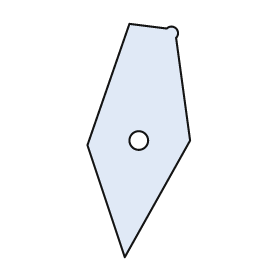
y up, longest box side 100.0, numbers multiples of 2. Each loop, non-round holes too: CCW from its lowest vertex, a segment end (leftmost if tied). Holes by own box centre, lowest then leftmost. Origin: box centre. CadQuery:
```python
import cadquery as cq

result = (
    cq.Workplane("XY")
    .moveTo(-6.0, -50.0)
    .lineTo(22.0, 0.0)
    .lineTo(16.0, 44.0)
    .threePointArc((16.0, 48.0), (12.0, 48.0))
    .lineTo(-4.0, 50.0)
    .lineTo(-22.0, -2.0)
    .close()
    .moveTo(0.0, 0.0)
    .circle(4.0)
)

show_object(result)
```